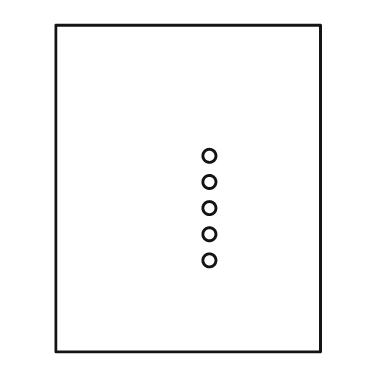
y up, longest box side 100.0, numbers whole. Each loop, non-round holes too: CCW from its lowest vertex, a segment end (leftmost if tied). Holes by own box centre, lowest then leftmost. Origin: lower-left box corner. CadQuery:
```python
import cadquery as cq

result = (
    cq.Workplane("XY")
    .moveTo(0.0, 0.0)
    .lineTo(81.0, 0.0)
    .lineTo(81.0, 100.0)
    .lineTo(0.0, 100.0)
    .close()
    .moveTo(47.0, 28.0)
    .circle(2.0)
    .moveTo(47.0, 36.0)
    .circle(2.0)
    .moveTo(47.0, 44.0)
    .circle(2.0)
    .moveTo(47.0, 52.0)
    .circle(2.0)
    .moveTo(47.0, 60.0)
    .circle(2.0)
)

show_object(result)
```